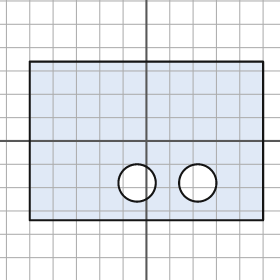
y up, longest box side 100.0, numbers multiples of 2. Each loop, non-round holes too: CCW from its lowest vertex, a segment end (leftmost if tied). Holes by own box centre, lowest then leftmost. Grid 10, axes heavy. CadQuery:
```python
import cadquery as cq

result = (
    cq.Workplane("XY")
    .moveTo(-50.0, -34.0)
    .lineTo(50.0, -34.0)
    .lineTo(50.0, 34.0)
    .lineTo(-50.0, 34.0)
    .close()
    .moveTo(-4.0, -18.0)
    .circle(8.0)
    .moveTo(22.0, -18.0)
    .circle(8.0)
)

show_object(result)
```